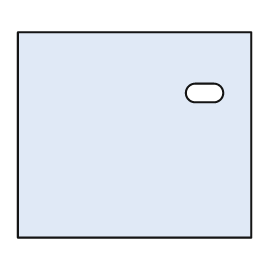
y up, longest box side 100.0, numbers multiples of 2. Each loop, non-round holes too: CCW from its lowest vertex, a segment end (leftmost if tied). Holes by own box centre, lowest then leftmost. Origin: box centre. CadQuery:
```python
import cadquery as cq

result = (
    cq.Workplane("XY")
    .moveTo(-50.0, -44.0)
    .lineTo(50.0, -44.0)
    .lineTo(50.0, 44.0)
    .lineTo(-50.0, 44.0)
    .close()
    .moveTo(26.0, 14.0)
    .lineTo(34.0, 14.0)
    .threePointArc((38.0, 18.0), (34.0, 22.0))
    .lineTo(26.0, 22.0)
    .threePointArc((22.0, 18.0), (26.0, 14.0))
    .close()
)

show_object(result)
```